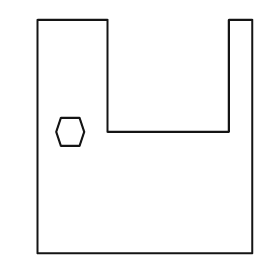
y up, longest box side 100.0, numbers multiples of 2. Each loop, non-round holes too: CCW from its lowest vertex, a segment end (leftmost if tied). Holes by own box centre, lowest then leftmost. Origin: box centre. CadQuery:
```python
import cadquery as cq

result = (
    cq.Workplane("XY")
    .moveTo(-46.0, -50.0)
    .lineTo(46.0, -50.0)
    .lineTo(46.0, 50.0)
    .lineTo(36.0, 50.0)
    .lineTo(36.0, 2.0)
    .lineTo(-16.0, 2.0)
    .lineTo(-16.0, 50.0)
    .lineTo(-46.0, 50.0)
    .close()
    .moveTo(-36.0, -4.0)
    .lineTo(-28.0, -4.0)
    .lineTo(-26.0, 2.0)
    .lineTo(-28.0, 8.0)
    .lineTo(-36.0, 8.0)
    .lineTo(-38.0, 2.0)
    .close()
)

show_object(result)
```